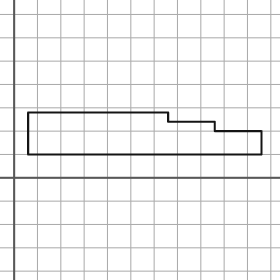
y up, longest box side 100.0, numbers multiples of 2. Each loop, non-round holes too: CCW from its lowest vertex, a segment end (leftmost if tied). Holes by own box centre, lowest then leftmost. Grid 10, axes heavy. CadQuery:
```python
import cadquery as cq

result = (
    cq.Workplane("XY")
    .moveTo(6.0, 10.0)
    .lineTo(106.0, 10.0)
    .lineTo(106.0, 20.0)
    .lineTo(86.0, 20.0)
    .lineTo(86.0, 24.0)
    .lineTo(66.0, 24.0)
    .lineTo(66.0, 28.0)
    .lineTo(6.0, 28.0)
    .close()
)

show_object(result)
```